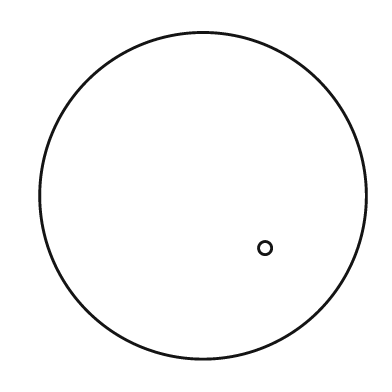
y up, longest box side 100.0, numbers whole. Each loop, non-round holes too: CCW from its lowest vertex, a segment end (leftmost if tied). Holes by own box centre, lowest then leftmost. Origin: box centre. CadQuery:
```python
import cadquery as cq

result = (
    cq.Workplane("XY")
    .moveTo(0.0, 0.0)
    .circle(50.0)
    .moveTo(19.0, -16.0)
    .circle(2.0)
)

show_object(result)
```